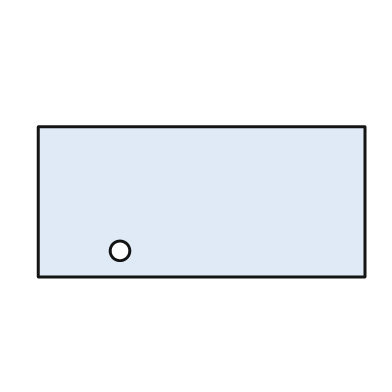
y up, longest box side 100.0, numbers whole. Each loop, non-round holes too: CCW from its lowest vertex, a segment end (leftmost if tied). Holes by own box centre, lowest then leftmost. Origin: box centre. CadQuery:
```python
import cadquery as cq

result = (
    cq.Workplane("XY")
    .moveTo(-50.0, -23.0)
    .lineTo(50.0, -23.0)
    .lineTo(50.0, 23.0)
    .lineTo(-50.0, 23.0)
    .close()
    .moveTo(-25.0, -15.0)
    .circle(3.0)
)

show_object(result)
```